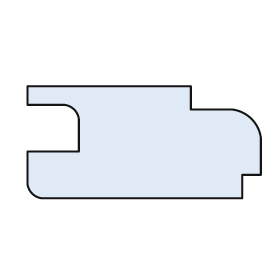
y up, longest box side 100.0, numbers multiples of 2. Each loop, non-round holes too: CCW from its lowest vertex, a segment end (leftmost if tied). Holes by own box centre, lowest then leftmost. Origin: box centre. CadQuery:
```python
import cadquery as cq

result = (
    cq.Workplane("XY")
    .moveTo(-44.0, -24.0)
    .lineTo(42.0, -24.0)
    .lineTo(42.0, -14.0)
    .lineTo(50.0, -14.0)
    .lineTo(50.0, 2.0)
    .threePointArc((46.0, 10.0), (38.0, 14.0))
    .lineTo(20.0, 14.0)
    .lineTo(20.0, 24.0)
    .lineTo(-50.0, 24.0)
    .lineTo(-50.0, 16.0)
    .lineTo(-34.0, 16.0)
    .threePointArc((-30.0, 14.0), (-28.0, 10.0))
    .lineTo(-28.0, -4.0)
    .lineTo(-50.0, -4.0)
    .lineTo(-50.0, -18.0)
    .threePointArc((-48.0, -22.0), (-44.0, -24.0))
    .close()
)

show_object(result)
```